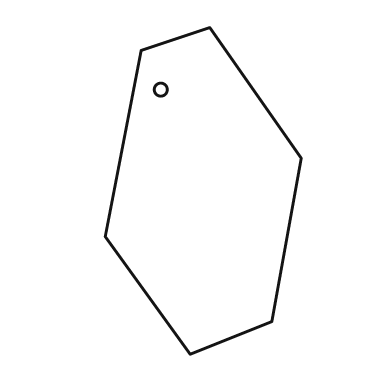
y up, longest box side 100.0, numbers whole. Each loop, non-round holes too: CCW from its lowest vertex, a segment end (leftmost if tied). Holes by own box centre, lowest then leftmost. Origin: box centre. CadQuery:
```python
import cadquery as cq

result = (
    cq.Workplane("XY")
    .moveTo(-4.0, -50.0)
    .lineTo(21.0, -40.0)
    .lineTo(30.0, 10.0)
    .lineTo(2.0, 50.0)
    .lineTo(-19.0, 43.0)
    .lineTo(-30.0, -14.0)
    .close()
    .moveTo(-13.0, 31.0)
    .circle(2.0)
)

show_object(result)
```